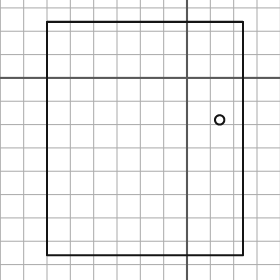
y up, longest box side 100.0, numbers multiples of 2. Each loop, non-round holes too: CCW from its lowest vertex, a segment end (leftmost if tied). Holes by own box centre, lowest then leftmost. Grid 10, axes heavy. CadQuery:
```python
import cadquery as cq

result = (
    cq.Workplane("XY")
    .moveTo(-60.0, -76.0)
    .lineTo(24.0, -76.0)
    .lineTo(24.0, 24.0)
    .lineTo(-60.0, 24.0)
    .close()
    .moveTo(14.0, -18.0)
    .circle(2.0)
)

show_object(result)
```